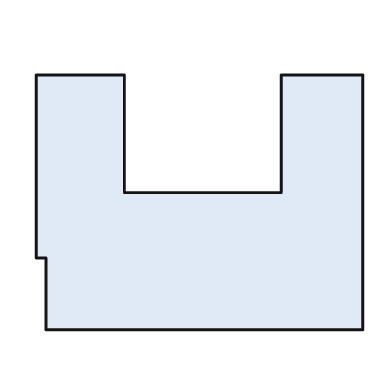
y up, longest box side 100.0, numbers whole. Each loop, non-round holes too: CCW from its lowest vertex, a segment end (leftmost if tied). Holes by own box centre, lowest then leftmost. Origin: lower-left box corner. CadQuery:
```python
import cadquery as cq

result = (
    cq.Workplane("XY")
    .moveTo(3.0, 0.0)
    .lineTo(100.0, 0.0)
    .lineTo(100.0, 78.0)
    .lineTo(75.0, 78.0)
    .lineTo(75.0, 42.0)
    .lineTo(27.0, 42.0)
    .lineTo(27.0, 78.0)
    .lineTo(0.0, 78.0)
    .lineTo(0.0, 22.0)
    .lineTo(3.0, 22.0)
    .close()
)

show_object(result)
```